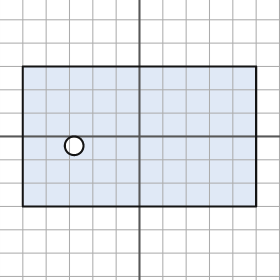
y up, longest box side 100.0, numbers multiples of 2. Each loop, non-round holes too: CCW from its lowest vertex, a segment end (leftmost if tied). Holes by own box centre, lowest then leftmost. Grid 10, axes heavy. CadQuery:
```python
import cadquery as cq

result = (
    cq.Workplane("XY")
    .moveTo(-50.0, -30.0)
    .lineTo(50.0, -30.0)
    .lineTo(50.0, 30.0)
    .lineTo(-50.0, 30.0)
    .close()
    .moveTo(-28.0, -4.0)
    .circle(4.0)
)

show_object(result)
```